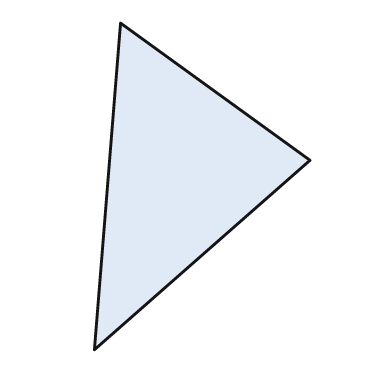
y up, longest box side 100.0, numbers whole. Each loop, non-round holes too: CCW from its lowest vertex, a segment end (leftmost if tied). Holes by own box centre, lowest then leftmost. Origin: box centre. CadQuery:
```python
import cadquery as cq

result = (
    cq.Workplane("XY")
    .moveTo(-33.0, -50.0)
    .lineTo(33.0, 8.0)
    .lineTo(-25.0, 50.0)
    .close()
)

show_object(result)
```